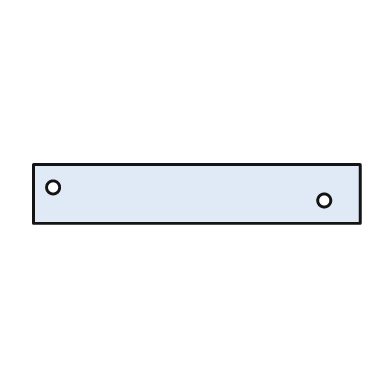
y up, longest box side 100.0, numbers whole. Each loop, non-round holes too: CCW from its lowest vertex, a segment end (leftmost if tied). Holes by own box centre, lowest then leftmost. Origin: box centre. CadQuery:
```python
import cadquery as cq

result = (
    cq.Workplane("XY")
    .moveTo(-50.0, -9.0)
    .lineTo(50.0, -9.0)
    .lineTo(50.0, 9.0)
    .lineTo(-50.0, 9.0)
    .close()
    .moveTo(39.0, -2.0)
    .circle(2.0)
    .moveTo(-44.0, 2.0)
    .circle(2.0)
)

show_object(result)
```